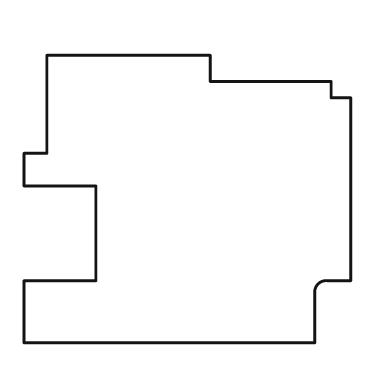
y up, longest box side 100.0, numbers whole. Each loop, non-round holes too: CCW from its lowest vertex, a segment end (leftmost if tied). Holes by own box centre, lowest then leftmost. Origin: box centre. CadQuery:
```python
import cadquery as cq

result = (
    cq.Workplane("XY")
    .moveTo(-50.0, -44.0)
    .lineTo(39.0, -44.0)
    .lineTo(39.0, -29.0)
    .threePointArc((40.0, -26.0), (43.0, -25.0))
    .lineTo(50.0, -25.0)
    .lineTo(50.0, 31.0)
    .lineTo(44.0, 31.0)
    .lineTo(44.0, 36.0)
    .lineTo(7.0, 36.0)
    .lineTo(7.0, 44.0)
    .lineTo(-43.0, 44.0)
    .lineTo(-43.0, 14.0)
    .lineTo(-50.0, 14.0)
    .lineTo(-50.0, 4.0)
    .lineTo(-28.0, 4.0)
    .lineTo(-28.0, -25.0)
    .lineTo(-50.0, -25.0)
    .close()
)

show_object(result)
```